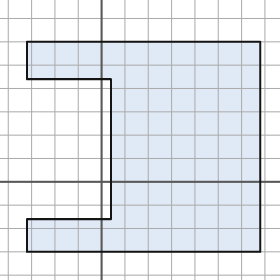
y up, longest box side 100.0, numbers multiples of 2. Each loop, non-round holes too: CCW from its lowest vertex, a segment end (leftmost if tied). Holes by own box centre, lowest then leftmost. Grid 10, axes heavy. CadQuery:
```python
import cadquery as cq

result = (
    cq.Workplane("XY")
    .moveTo(-32.0, -30.0)
    .lineTo(68.0, -30.0)
    .lineTo(68.0, 60.0)
    .lineTo(-32.0, 60.0)
    .lineTo(-32.0, 44.0)
    .lineTo(4.0, 44.0)
    .lineTo(4.0, -16.0)
    .lineTo(-32.0, -16.0)
    .close()
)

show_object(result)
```